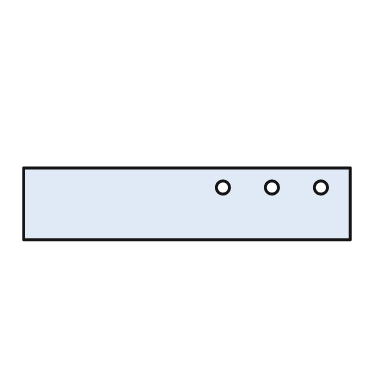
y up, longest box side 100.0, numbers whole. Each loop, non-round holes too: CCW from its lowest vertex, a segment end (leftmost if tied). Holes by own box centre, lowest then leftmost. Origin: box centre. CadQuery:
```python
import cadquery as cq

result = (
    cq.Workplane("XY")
    .moveTo(-50.0, -11.0)
    .lineTo(50.0, -11.0)
    .lineTo(50.0, 11.0)
    .lineTo(-50.0, 11.0)
    .close()
    .moveTo(11.0, 5.0)
    .circle(2.0)
    .moveTo(26.0, 5.0)
    .circle(2.0)
    .moveTo(41.0, 5.0)
    .circle(2.0)
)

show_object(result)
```